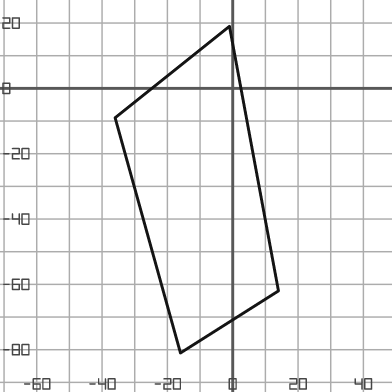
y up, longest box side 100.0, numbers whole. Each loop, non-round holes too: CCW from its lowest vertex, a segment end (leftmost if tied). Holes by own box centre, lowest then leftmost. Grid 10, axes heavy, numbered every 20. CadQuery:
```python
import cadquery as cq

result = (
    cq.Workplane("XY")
    .moveTo(-16.0, -81.0)
    .lineTo(14.0, -62.0)
    .lineTo(-1.0, 19.0)
    .lineTo(-36.0, -9.0)
    .close()
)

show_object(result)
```